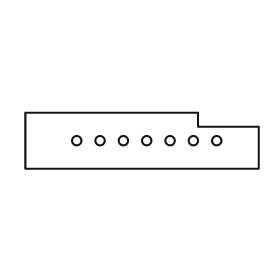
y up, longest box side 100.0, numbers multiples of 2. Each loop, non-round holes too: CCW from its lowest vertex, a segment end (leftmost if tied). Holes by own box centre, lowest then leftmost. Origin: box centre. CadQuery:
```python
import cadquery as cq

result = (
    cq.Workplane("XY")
    .moveTo(-50.0, -12.0)
    .lineTo(50.0, -12.0)
    .lineTo(50.0, 6.0)
    .lineTo(24.0, 6.0)
    .lineTo(24.0, 12.0)
    .lineTo(-50.0, 12.0)
    .close()
    .moveTo(-28.0, 0.0)
    .circle(2.0)
    .moveTo(-18.0, 0.0)
    .circle(2.0)
    .moveTo(-8.0, 0.0)
    .circle(2.0)
    .moveTo(2.0, 0.0)
    .circle(2.0)
    .moveTo(12.0, 0.0)
    .circle(2.0)
    .moveTo(22.0, 0.0)
    .circle(2.0)
    .moveTo(32.0, 0.0)
    .circle(2.0)
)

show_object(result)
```